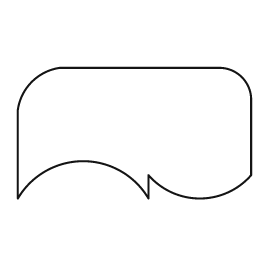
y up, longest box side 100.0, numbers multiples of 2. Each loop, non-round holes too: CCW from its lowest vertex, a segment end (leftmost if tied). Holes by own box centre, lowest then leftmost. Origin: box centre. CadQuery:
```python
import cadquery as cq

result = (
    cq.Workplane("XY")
    .moveTo(-50.0, -28.0)
    .threePointArc((-22.0, -12.0), (6.0, -28.0))
    .lineTo(6.0, -18.0)
    .threePointArc((28.0, -28.0), (50.0, -18.0))
    .lineTo(50.0, 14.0)
    .threePointArc((46.0, 24.0), (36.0, 28.0))
    .lineTo(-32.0, 28.0)
    .threePointArc((-44.0, 22.0), (-50.0, 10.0))
    .close()
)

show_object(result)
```